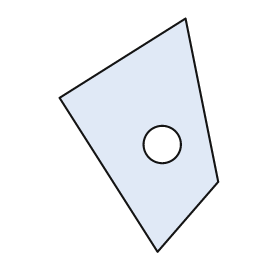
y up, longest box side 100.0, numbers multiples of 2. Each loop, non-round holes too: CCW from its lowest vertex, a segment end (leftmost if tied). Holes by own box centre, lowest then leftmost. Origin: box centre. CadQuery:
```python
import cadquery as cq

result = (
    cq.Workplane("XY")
    .moveTo(8.0, -50.0)
    .lineTo(34.0, -20.0)
    .lineTo(20.0, 50.0)
    .lineTo(-34.0, 16.0)
    .close()
    .moveTo(10.0, -4.0)
    .circle(8.0)
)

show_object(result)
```